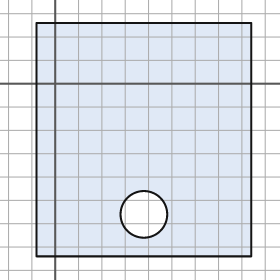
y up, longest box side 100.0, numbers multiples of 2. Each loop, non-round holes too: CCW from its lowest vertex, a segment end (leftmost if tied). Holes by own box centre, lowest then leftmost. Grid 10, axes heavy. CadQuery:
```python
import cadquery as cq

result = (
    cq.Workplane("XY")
    .moveTo(-8.0, -74.0)
    .lineTo(84.0, -74.0)
    .lineTo(84.0, 26.0)
    .lineTo(-8.0, 26.0)
    .close()
    .moveTo(38.0, -56.0)
    .circle(10.0)
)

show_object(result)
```